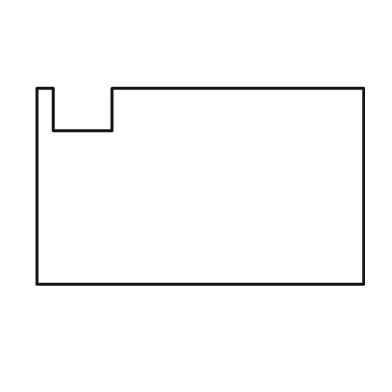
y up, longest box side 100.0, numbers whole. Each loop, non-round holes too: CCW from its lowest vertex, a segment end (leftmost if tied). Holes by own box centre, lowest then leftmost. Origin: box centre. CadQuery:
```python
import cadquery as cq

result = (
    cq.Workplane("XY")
    .moveTo(-50.0, -30.0)
    .lineTo(50.0, -30.0)
    .lineTo(50.0, 30.0)
    .lineTo(-27.0, 30.0)
    .lineTo(-27.0, 17.0)
    .lineTo(-45.0, 17.0)
    .lineTo(-45.0, 30.0)
    .lineTo(-50.0, 30.0)
    .close()
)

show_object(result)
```